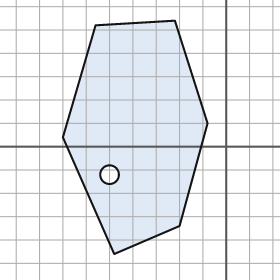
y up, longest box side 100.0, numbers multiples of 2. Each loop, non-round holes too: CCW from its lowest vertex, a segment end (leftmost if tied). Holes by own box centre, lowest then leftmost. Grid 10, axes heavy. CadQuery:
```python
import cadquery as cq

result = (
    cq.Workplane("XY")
    .moveTo(-48.0, -46.0)
    .lineTo(-20.0, -34.0)
    .lineTo(-8.0, 10.0)
    .lineTo(-22.0, 54.0)
    .lineTo(-56.0, 52.0)
    .lineTo(-70.0, 4.0)
    .close()
    .moveTo(-50.0, -12.0)
    .circle(4.0)
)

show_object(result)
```